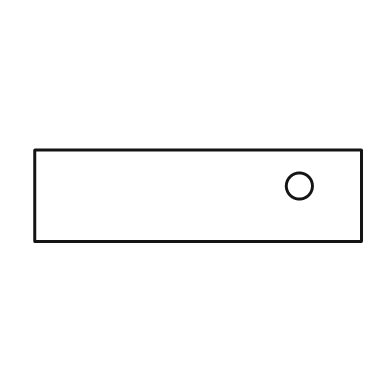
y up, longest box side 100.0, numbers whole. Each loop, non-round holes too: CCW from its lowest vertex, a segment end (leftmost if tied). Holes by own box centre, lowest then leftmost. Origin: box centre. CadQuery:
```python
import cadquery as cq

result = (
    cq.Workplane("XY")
    .moveTo(-50.0, -14.0)
    .lineTo(50.0, -14.0)
    .lineTo(50.0, 14.0)
    .lineTo(-50.0, 14.0)
    .close()
    .moveTo(31.0, 3.0)
    .circle(4.0)
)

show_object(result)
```